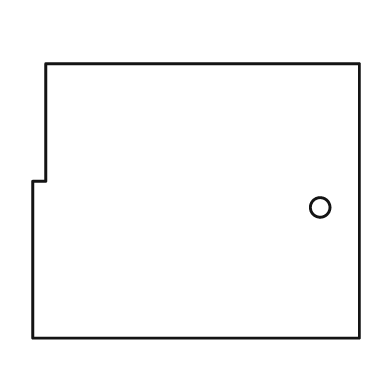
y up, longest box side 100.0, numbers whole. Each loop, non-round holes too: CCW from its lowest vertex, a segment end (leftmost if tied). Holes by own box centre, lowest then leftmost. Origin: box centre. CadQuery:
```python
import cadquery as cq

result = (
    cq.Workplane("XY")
    .moveTo(-50.0, -42.0)
    .lineTo(50.0, -42.0)
    .lineTo(50.0, 42.0)
    .lineTo(-46.0, 42.0)
    .lineTo(-46.0, 6.0)
    .lineTo(-50.0, 6.0)
    .close()
    .moveTo(38.0, -2.0)
    .circle(3.0)
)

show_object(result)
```